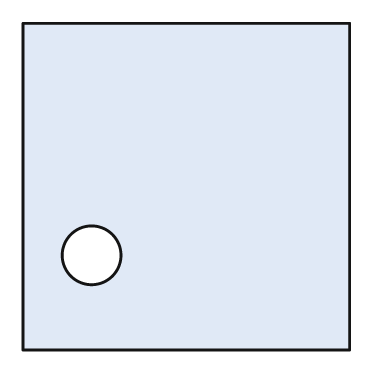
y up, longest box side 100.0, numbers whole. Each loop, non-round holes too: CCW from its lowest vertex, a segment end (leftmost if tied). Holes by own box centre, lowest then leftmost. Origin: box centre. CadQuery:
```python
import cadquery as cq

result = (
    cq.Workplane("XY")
    .moveTo(-50.0, -50.0)
    .lineTo(50.0, -50.0)
    .lineTo(50.0, 50.0)
    .lineTo(-50.0, 50.0)
    .close()
    .moveTo(-29.0, -21.0)
    .circle(9.0)
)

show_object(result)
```